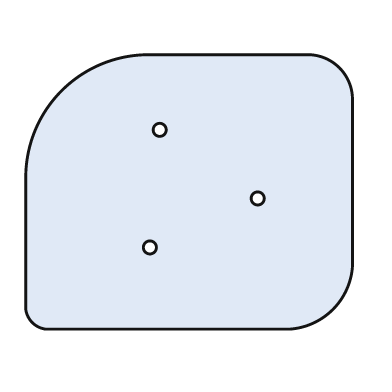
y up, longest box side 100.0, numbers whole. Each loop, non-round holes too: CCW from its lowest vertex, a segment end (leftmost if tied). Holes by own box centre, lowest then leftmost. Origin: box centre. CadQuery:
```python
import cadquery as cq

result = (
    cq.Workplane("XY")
    .moveTo(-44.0, -42.0)
    .lineTo(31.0, -42.0)
    .threePointArc((44.0, -36.0), (50.0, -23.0))
    .lineTo(50.0, 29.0)
    .threePointArc((46.0, 38.0), (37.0, 42.0))
    .lineTo(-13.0, 42.0)
    .threePointArc((-39.0, 31.0), (-50.0, 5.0))
    .lineTo(-50.0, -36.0)
    .threePointArc((-48.0, -40.0), (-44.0, -42.0))
    .close()
    .moveTo(-12.0, -17.0)
    .circle(2.0)
    .moveTo(21.0, -2.0)
    .circle(2.0)
    .moveTo(-9.0, 19.0)
    .circle(2.0)
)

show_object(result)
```